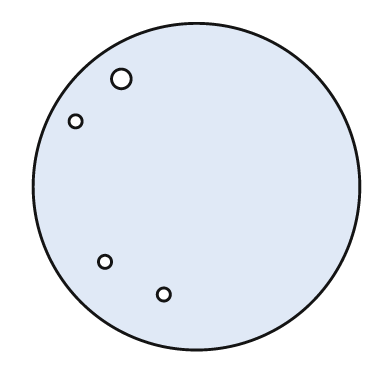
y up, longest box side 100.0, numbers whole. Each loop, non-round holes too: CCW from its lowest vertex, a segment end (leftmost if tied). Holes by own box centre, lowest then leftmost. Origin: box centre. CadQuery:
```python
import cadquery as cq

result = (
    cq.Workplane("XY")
    .moveTo(0.0, 0.0)
    .circle(50.0)
    .moveTo(-10.0, -33.0)
    .circle(2.0)
    .moveTo(-28.0, -23.0)
    .circle(2.0)
    .moveTo(-37.0, 20.0)
    .circle(2.0)
    .moveTo(-23.0, 33.0)
    .circle(3.0)
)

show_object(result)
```